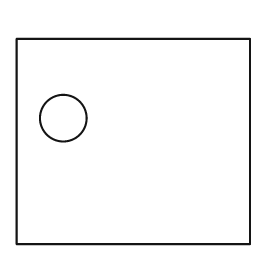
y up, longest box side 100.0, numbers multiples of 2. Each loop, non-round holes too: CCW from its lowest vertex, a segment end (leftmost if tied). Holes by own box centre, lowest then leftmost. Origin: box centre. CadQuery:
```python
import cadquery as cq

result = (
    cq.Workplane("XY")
    .moveTo(-50.0, -44.0)
    .lineTo(50.0, -44.0)
    .lineTo(50.0, 44.0)
    .lineTo(-50.0, 44.0)
    .close()
    .moveTo(-30.0, 10.0)
    .circle(10.0)
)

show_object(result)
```